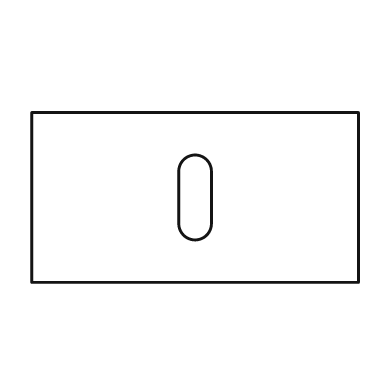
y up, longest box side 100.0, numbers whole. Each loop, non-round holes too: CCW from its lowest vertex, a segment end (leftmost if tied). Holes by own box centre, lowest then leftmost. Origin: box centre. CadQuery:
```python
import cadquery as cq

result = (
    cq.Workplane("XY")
    .moveTo(-50.0, -26.0)
    .lineTo(50.0, -26.0)
    .lineTo(50.0, 26.0)
    .lineTo(-50.0, 26.0)
    .close()
    .moveTo(-5.0, -8.0)
    .threePointArc((0.0, -13.0), (5.0, -8.0))
    .lineTo(5.0, 8.0)
    .threePointArc((0.0, 13.0), (-5.0, 8.0))
    .close()
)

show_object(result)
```